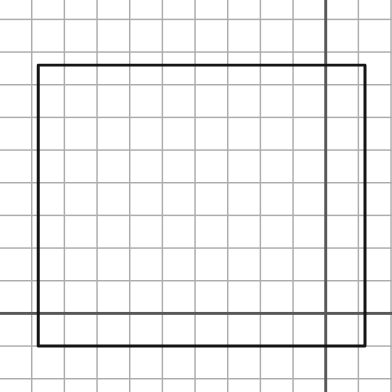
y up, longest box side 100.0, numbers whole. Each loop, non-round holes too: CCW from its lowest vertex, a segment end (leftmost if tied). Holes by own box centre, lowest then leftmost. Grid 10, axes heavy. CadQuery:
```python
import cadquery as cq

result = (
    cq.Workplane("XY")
    .moveTo(-88.0, -10.0)
    .lineTo(12.0, -10.0)
    .lineTo(12.0, 76.0)
    .lineTo(-88.0, 76.0)
    .close()
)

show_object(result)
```